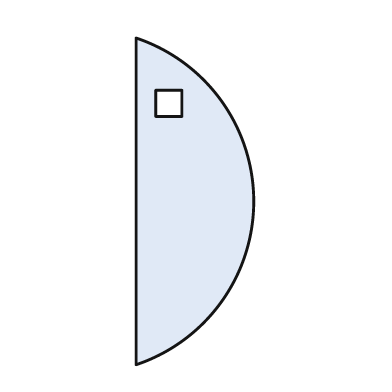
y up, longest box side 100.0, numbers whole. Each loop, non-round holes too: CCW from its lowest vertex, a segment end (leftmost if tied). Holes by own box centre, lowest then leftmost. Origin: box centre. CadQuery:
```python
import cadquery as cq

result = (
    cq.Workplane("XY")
    .moveTo(-18.0, -50.0)
    .threePointArc((18.0, 0.0), (-18.0, 50.0))
    .close()
    .moveTo(-12.0, 26.0)
    .lineTo(-4.0, 26.0)
    .lineTo(-4.0, 34.0)
    .lineTo(-12.0, 34.0)
    .close()
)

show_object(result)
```